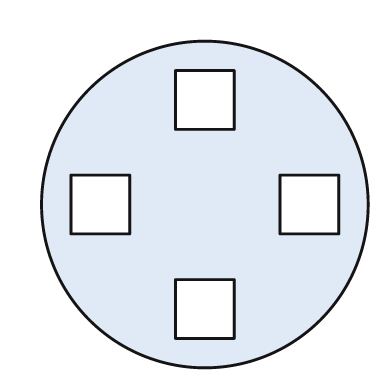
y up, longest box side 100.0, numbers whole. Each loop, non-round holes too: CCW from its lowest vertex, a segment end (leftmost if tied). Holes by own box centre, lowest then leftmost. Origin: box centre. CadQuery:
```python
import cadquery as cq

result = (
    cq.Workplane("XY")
    .moveTo(0.0, 0.0)
    .circle(50.0)
    .moveTo(-9.0, -41.0)
    .lineTo(9.0, -41.0)
    .lineTo(9.0, -23.0)
    .lineTo(-9.0, -23.0)
    .close()
    .moveTo(-41.0, -9.0)
    .lineTo(-23.0, -9.0)
    .lineTo(-23.0, 9.0)
    .lineTo(-41.0, 9.0)
    .close()
    .moveTo(23.0, -9.0)
    .lineTo(41.0, -9.0)
    .lineTo(41.0, 9.0)
    .lineTo(23.0, 9.0)
    .close()
    .moveTo(-9.0, 23.0)
    .lineTo(9.0, 23.0)
    .lineTo(9.0, 41.0)
    .lineTo(-9.0, 41.0)
    .close()
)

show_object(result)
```